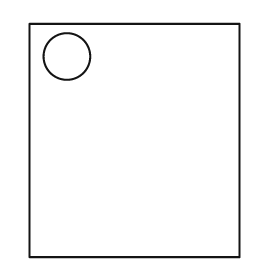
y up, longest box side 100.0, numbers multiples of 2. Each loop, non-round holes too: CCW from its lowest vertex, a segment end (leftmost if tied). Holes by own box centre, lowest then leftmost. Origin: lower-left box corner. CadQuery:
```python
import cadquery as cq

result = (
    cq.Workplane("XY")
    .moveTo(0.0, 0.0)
    .lineTo(90.0, 0.0)
    .lineTo(90.0, 100.0)
    .lineTo(0.0, 100.0)
    .close()
    .moveTo(16.0, 86.0)
    .circle(10.0)
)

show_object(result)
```